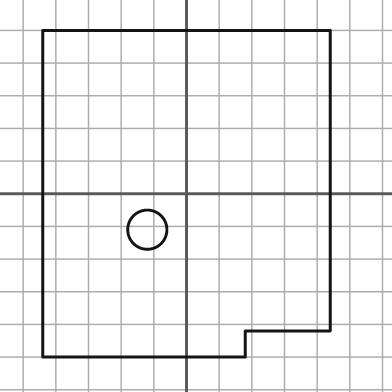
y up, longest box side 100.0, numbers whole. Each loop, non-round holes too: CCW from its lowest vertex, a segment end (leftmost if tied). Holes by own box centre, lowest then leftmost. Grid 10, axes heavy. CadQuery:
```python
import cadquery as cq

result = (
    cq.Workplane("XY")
    .moveTo(-44.0, -50.0)
    .lineTo(18.0, -50.0)
    .lineTo(18.0, -42.0)
    .lineTo(44.0, -42.0)
    .lineTo(44.0, 50.0)
    .lineTo(-44.0, 50.0)
    .close()
    .moveTo(-12.0, -11.0)
    .circle(6.0)
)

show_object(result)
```